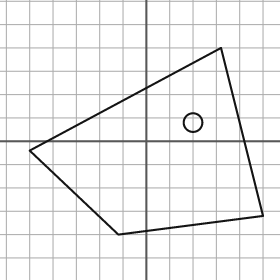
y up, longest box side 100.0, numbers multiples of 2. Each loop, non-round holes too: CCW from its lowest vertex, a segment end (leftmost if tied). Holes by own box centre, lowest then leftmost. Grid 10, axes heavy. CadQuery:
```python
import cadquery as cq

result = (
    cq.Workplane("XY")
    .moveTo(-12.0, -40.0)
    .lineTo(50.0, -32.0)
    .lineTo(32.0, 40.0)
    .lineTo(-50.0, -4.0)
    .close()
    .moveTo(20.0, 8.0)
    .circle(4.0)
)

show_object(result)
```